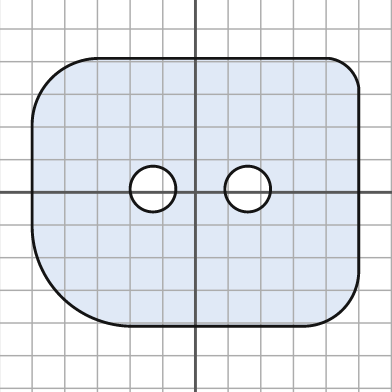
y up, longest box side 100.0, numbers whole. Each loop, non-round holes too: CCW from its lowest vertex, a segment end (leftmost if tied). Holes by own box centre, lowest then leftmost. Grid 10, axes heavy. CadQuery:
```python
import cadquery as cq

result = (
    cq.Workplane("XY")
    .moveTo(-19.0, -41.0)
    .lineTo(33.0, -41.0)
    .threePointArc((45.0, -36.0), (50.0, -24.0))
    .lineTo(50.0, 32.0)
    .threePointArc((47.0, 38.0), (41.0, 41.0))
    .lineTo(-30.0, 41.0)
    .threePointArc((-44.0, 35.0), (-50.0, 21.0))
    .lineTo(-50.0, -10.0)
    .threePointArc((-41.0, -32.0), (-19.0, -41.0))
    .close()
    .moveTo(-13.0, 1.0)
    .circle(7.0)
    .moveTo(16.0, 1.0)
    .circle(7.0)
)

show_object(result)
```